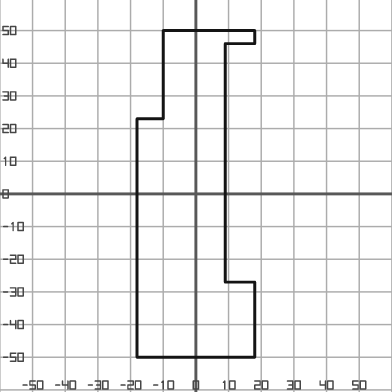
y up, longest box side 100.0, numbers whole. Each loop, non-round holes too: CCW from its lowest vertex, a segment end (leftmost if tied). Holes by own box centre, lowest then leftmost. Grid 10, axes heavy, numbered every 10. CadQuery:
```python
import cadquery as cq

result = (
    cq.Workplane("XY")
    .moveTo(-18.0, -50.0)
    .lineTo(18.0, -50.0)
    .lineTo(18.0, -27.0)
    .lineTo(9.0, -27.0)
    .lineTo(9.0, 46.0)
    .lineTo(18.0, 46.0)
    .lineTo(18.0, 50.0)
    .lineTo(-10.0, 50.0)
    .lineTo(-10.0, 23.0)
    .lineTo(-18.0, 23.0)
    .close()
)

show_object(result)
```